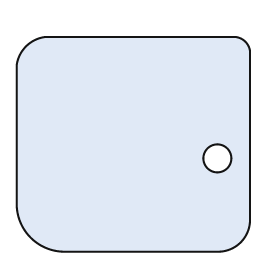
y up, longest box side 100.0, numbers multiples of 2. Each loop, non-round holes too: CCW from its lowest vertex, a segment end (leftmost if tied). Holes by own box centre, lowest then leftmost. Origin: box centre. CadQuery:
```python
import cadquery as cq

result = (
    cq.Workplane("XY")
    .moveTo(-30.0, -46.0)
    .lineTo(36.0, -46.0)
    .threePointArc((46.0, -42.0), (50.0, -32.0))
    .lineTo(50.0, 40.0)
    .threePointArc((48.0, 44.0), (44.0, 46.0))
    .lineTo(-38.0, 46.0)
    .threePointArc((-46.0, 42.0), (-50.0, 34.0))
    .lineTo(-50.0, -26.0)
    .threePointArc((-44.0, -40.0), (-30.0, -46.0))
    .close()
    .moveTo(36.0, -6.0)
    .circle(6.0)
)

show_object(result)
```